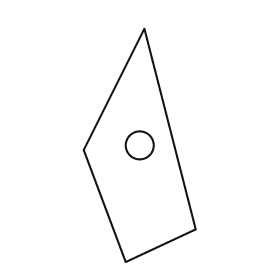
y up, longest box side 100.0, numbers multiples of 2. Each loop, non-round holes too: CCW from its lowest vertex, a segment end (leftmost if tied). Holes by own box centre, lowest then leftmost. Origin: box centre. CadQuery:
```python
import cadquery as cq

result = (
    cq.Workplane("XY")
    .moveTo(-6.0, -50.0)
    .lineTo(24.0, -36.0)
    .lineTo(2.0, 50.0)
    .lineTo(-24.0, -2.0)
    .close()
    .moveTo(0.0, 0.0)
    .circle(6.0)
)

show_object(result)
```